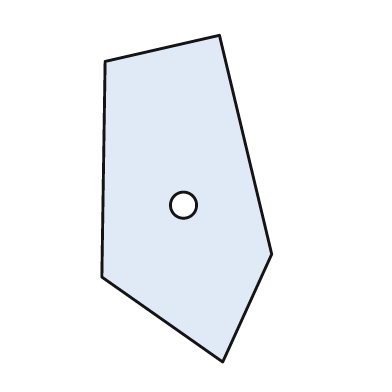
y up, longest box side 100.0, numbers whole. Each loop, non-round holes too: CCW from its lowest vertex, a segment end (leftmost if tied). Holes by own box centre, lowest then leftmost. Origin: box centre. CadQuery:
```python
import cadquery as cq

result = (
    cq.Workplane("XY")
    .moveTo(11.0, -50.0)
    .lineTo(26.0, -17.0)
    .lineTo(10.0, 50.0)
    .lineTo(-25.0, 42.0)
    .lineTo(-26.0, -24.0)
    .close()
    .moveTo(-1.0, -2.0)
    .circle(4.0)
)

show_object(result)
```